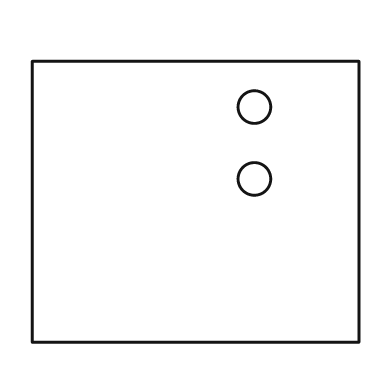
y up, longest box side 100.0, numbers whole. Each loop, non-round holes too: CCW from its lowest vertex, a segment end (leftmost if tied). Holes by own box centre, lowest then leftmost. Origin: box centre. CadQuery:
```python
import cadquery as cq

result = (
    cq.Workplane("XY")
    .moveTo(-50.0, -43.0)
    .lineTo(50.0, -43.0)
    .lineTo(50.0, 43.0)
    .lineTo(-50.0, 43.0)
    .close()
    .moveTo(18.0, 7.0)
    .circle(5.0)
    .moveTo(18.0, 29.0)
    .circle(5.0)
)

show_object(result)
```